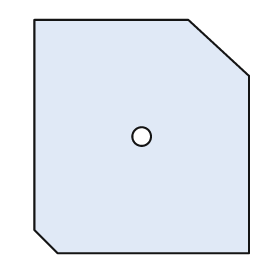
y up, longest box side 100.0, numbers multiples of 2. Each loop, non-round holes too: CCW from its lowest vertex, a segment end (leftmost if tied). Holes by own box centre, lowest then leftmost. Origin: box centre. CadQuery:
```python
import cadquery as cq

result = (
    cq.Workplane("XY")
    .moveTo(-36.0, -50.0)
    .lineTo(46.0, -50.0)
    .lineTo(46.0, 26.0)
    .lineTo(20.0, 50.0)
    .lineTo(-46.0, 50.0)
    .lineTo(-46.0, -40.0)
    .close()
    .moveTo(0.0, 0.0)
    .circle(4.0)
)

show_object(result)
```